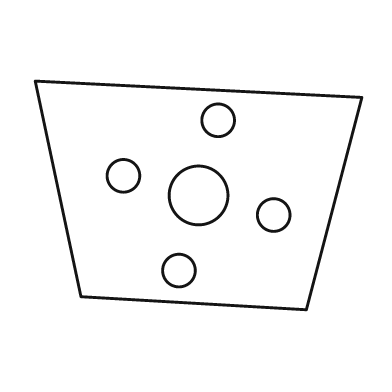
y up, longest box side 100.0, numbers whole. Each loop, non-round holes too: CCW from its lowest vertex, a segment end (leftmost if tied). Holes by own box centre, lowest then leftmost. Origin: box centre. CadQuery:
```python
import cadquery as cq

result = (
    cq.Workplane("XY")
    .moveTo(33.0, -35.0)
    .lineTo(50.0, 30.0)
    .lineTo(-50.0, 35.0)
    .lineTo(-36.0, -31.0)
    .close()
    .moveTo(-6.0, -23.0)
    .circle(5.0)
    .moveTo(23.0, -6.0)
    .circle(5.0)
    .moveTo(0.0, 0.0)
    .circle(9.0)
    .moveTo(-23.0, 6.0)
    .circle(5.0)
    .moveTo(6.0, 23.0)
    .circle(5.0)
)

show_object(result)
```